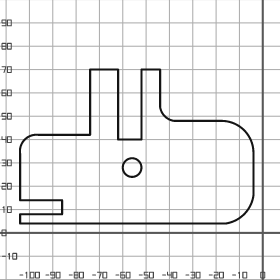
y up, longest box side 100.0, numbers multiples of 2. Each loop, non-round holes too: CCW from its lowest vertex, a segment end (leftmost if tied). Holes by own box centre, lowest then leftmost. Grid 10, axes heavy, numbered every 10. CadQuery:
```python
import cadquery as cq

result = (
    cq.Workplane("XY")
    .moveTo(-104.0, 4.0)
    .lineTo(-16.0, 4.0)
    .threePointArc((-8.0, 8.0), (-4.0, 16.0))
    .lineTo(-4.0, 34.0)
    .threePointArc((-8.0, 44.0), (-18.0, 48.0))
    .lineTo(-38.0, 48.0)
    .threePointArc((-42.0, 50.0), (-44.0, 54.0))
    .lineTo(-44.0, 70.0)
    .lineTo(-52.0, 70.0)
    .lineTo(-52.0, 40.0)
    .lineTo(-62.0, 40.0)
    .lineTo(-62.0, 70.0)
    .lineTo(-74.0, 70.0)
    .lineTo(-74.0, 42.0)
    .lineTo(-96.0, 42.0)
    .threePointArc((-102.0, 40.0), (-104.0, 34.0))
    .lineTo(-104.0, 14.0)
    .lineTo(-86.0, 14.0)
    .lineTo(-86.0, 8.0)
    .lineTo(-104.0, 8.0)
    .close()
    .moveTo(-56.0, 28.0)
    .circle(4.0)
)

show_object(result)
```